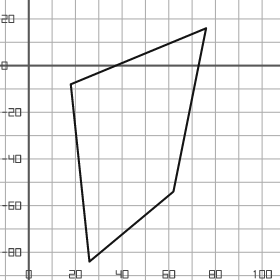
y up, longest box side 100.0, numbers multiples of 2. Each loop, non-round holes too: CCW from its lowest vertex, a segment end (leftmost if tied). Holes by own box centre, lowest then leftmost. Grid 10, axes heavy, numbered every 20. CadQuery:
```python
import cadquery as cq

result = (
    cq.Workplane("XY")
    .moveTo(26.0, -84.0)
    .lineTo(62.0, -54.0)
    .lineTo(76.0, 16.0)
    .lineTo(18.0, -8.0)
    .close()
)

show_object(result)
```